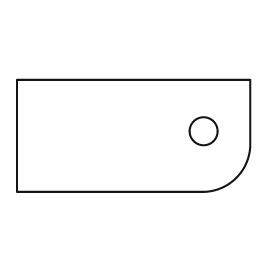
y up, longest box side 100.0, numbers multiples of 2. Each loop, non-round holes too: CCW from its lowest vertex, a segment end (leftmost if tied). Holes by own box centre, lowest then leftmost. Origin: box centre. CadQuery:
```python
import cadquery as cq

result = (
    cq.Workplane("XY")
    .moveTo(-50.0, -24.0)
    .lineTo(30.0, -24.0)
    .threePointArc((44.0, -18.0), (50.0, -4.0))
    .lineTo(50.0, 24.0)
    .lineTo(-50.0, 24.0)
    .close()
    .moveTo(30.0, 2.0)
    .circle(6.0)
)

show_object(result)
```